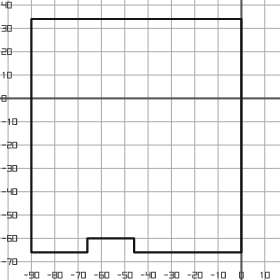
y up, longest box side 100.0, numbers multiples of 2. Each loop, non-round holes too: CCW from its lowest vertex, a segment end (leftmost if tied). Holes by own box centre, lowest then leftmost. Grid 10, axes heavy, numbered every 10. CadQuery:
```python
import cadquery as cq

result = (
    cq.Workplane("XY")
    .moveTo(-90.0, -66.0)
    .lineTo(-66.0, -66.0)
    .lineTo(-66.0, -60.0)
    .lineTo(-46.0, -60.0)
    .lineTo(-46.0, -66.0)
    .lineTo(0.0, -66.0)
    .lineTo(0.0, 34.0)
    .lineTo(-90.0, 34.0)
    .close()
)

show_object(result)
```